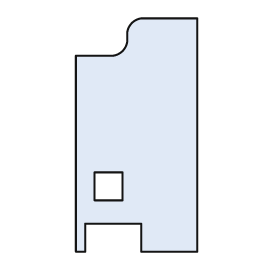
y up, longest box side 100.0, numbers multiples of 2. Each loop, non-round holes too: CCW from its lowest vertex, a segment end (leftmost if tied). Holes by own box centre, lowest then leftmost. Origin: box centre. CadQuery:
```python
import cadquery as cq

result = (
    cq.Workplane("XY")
    .moveTo(-26.0, -50.0)
    .lineTo(-22.0, -50.0)
    .lineTo(-22.0, -38.0)
    .lineTo(2.0, -38.0)
    .lineTo(2.0, -50.0)
    .lineTo(26.0, -50.0)
    .lineTo(26.0, 50.0)
    .lineTo(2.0, 50.0)
    .threePointArc((-2.0, 48.0), (-4.0, 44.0))
    .lineTo(-4.0, 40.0)
    .threePointArc((-6.0, 36.0), (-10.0, 34.0))
    .lineTo(-26.0, 34.0)
    .close()
    .moveTo(-18.0, -28.0)
    .lineTo(-6.0, -28.0)
    .lineTo(-6.0, -16.0)
    .lineTo(-18.0, -16.0)
    .close()
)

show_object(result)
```